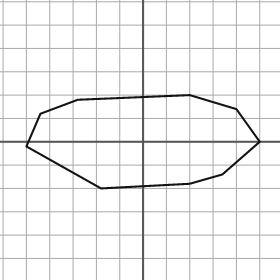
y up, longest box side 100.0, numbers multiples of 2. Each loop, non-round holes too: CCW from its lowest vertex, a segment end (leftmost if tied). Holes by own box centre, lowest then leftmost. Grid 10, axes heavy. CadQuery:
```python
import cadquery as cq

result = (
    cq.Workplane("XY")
    .moveTo(-18.0, -20.0)
    .lineTo(20.0, -18.0)
    .lineTo(34.0, -14.0)
    .lineTo(50.0, 0.0)
    .lineTo(40.0, 14.0)
    .lineTo(20.0, 20.0)
    .lineTo(-28.0, 18.0)
    .lineTo(-44.0, 12.0)
    .lineTo(-50.0, -2.0)
    .close()
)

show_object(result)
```